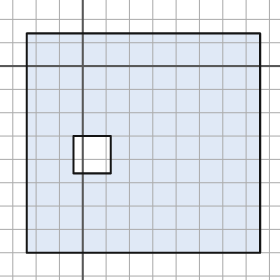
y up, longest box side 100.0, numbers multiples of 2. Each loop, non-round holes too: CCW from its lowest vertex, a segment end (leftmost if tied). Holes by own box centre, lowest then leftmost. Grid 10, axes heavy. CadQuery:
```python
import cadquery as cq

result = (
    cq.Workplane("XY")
    .moveTo(-24.0, -80.0)
    .lineTo(76.0, -80.0)
    .lineTo(76.0, 14.0)
    .lineTo(-24.0, 14.0)
    .close()
    .moveTo(-4.0, -46.0)
    .lineTo(12.0, -46.0)
    .lineTo(12.0, -30.0)
    .lineTo(-4.0, -30.0)
    .close()
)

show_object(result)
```